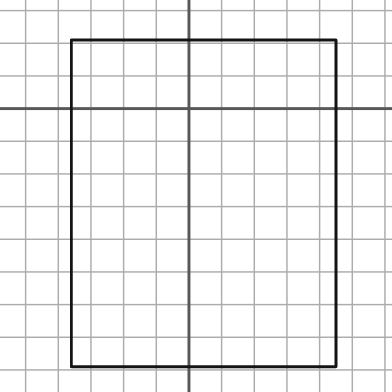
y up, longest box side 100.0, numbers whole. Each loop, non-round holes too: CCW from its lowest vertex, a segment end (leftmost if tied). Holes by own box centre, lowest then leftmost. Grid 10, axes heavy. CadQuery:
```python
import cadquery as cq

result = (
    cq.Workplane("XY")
    .moveTo(-36.0, -79.0)
    .lineTo(45.0, -79.0)
    .lineTo(45.0, 21.0)
    .lineTo(-36.0, 21.0)
    .close()
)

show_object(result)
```